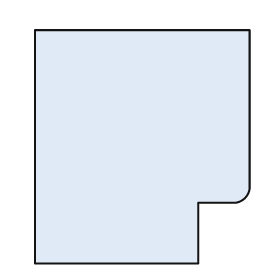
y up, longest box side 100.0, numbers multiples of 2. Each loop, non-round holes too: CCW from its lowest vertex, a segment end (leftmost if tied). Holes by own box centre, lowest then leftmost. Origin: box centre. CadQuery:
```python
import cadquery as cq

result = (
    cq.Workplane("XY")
    .moveTo(-46.0, -50.0)
    .lineTo(24.0, -50.0)
    .lineTo(24.0, -24.0)
    .lineTo(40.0, -24.0)
    .threePointArc((44.0, -22.0), (46.0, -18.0))
    .lineTo(46.0, 50.0)
    .lineTo(-46.0, 50.0)
    .close()
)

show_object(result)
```